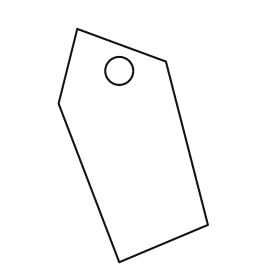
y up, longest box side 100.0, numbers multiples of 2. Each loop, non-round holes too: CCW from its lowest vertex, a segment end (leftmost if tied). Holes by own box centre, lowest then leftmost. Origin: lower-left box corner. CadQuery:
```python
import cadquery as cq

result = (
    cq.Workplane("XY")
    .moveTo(26.0, 0.0)
    .lineTo(64.0, 16.0)
    .lineTo(46.0, 86.0)
    .lineTo(8.0, 100.0)
    .lineTo(0.0, 68.0)
    .close()
    .moveTo(26.0, 82.0)
    .circle(6.0)
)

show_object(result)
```